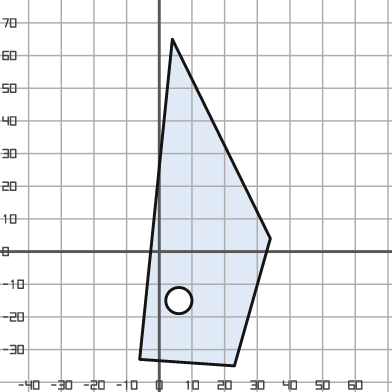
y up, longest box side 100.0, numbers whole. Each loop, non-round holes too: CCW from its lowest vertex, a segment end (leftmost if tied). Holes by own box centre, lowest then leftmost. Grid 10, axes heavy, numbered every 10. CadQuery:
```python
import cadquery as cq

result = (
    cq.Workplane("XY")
    .moveTo(23.0, -35.0)
    .lineTo(34.0, 4.0)
    .lineTo(4.0, 65.0)
    .lineTo(-6.0, -33.0)
    .close()
    .moveTo(6.0, -15.0)
    .circle(4.0)
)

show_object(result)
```